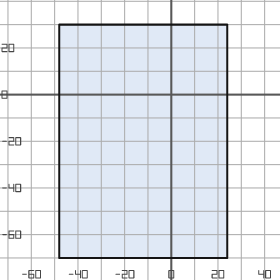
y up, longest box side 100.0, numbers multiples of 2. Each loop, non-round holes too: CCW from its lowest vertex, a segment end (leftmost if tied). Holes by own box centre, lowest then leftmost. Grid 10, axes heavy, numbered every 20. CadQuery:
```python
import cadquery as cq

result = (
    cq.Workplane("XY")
    .moveTo(-48.0, -70.0)
    .lineTo(24.0, -70.0)
    .lineTo(24.0, 30.0)
    .lineTo(-48.0, 30.0)
    .close()
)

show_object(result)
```